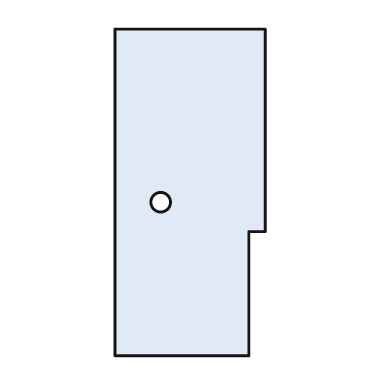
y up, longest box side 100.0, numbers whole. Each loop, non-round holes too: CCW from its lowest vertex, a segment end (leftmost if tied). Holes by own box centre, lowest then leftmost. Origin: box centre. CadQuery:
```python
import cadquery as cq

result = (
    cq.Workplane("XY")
    .moveTo(-23.0, -50.0)
    .lineTo(18.0, -50.0)
    .lineTo(18.0, -12.0)
    .lineTo(23.0, -12.0)
    .lineTo(23.0, 50.0)
    .lineTo(-23.0, 50.0)
    .close()
    .moveTo(-9.0, -3.0)
    .circle(3.0)
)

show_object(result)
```